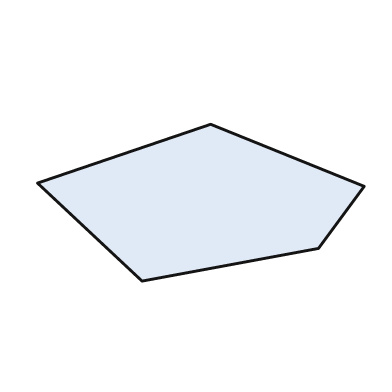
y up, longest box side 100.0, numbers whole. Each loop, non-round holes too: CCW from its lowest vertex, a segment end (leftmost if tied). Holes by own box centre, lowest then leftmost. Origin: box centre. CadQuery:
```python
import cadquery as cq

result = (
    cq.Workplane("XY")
    .moveTo(-18.0, -24.0)
    .lineTo(36.0, -14.0)
    .lineTo(50.0, 5.0)
    .lineTo(3.0, 24.0)
    .lineTo(-50.0, 6.0)
    .close()
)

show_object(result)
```